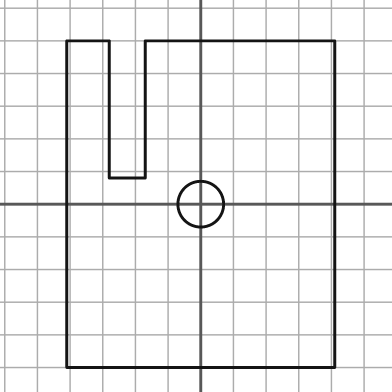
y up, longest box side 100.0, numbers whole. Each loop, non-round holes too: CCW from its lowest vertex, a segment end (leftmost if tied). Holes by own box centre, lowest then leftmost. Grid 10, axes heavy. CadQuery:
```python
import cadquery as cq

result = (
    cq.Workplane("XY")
    .moveTo(-41.0, -50.0)
    .lineTo(41.0, -50.0)
    .lineTo(41.0, 50.0)
    .lineTo(-17.0, 50.0)
    .lineTo(-17.0, 8.0)
    .lineTo(-28.0, 8.0)
    .lineTo(-28.0, 50.0)
    .lineTo(-41.0, 50.0)
    .close()
    .moveTo(0.0, 0.0)
    .circle(7.0)
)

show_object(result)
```